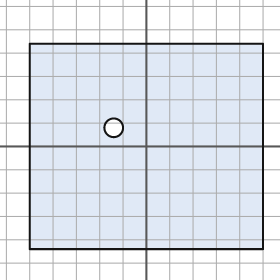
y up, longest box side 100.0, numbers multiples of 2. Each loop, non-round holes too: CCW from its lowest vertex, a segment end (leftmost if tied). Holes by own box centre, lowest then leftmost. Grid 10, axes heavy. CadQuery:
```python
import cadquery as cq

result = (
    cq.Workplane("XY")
    .moveTo(-50.0, -44.0)
    .lineTo(50.0, -44.0)
    .lineTo(50.0, 44.0)
    .lineTo(-50.0, 44.0)
    .close()
    .moveTo(-14.0, 8.0)
    .circle(4.0)
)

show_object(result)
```